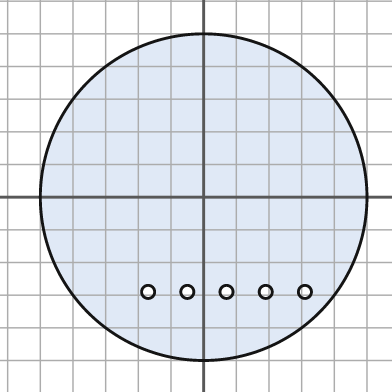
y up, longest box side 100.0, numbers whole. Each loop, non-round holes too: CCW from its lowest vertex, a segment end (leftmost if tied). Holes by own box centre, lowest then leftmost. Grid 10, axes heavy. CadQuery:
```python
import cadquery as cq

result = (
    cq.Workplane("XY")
    .moveTo(0.0, 0.0)
    .circle(50.0)
    .moveTo(-17.0, -29.0)
    .circle(2.0)
    .moveTo(-5.0, -29.0)
    .circle(2.0)
    .moveTo(7.0, -29.0)
    .circle(2.0)
    .moveTo(19.0, -29.0)
    .circle(2.0)
    .moveTo(31.0, -29.0)
    .circle(2.0)
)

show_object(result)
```